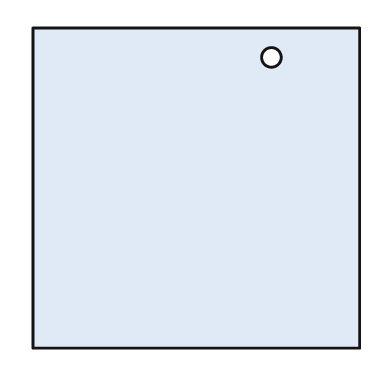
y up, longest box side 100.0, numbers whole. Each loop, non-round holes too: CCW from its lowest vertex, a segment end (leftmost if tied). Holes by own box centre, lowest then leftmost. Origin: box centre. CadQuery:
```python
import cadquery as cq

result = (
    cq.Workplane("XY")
    .moveTo(-50.0, -49.0)
    .lineTo(50.0, -49.0)
    .lineTo(50.0, 49.0)
    .lineTo(-50.0, 49.0)
    .close()
    .moveTo(23.0, 40.0)
    .circle(3.0)
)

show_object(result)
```